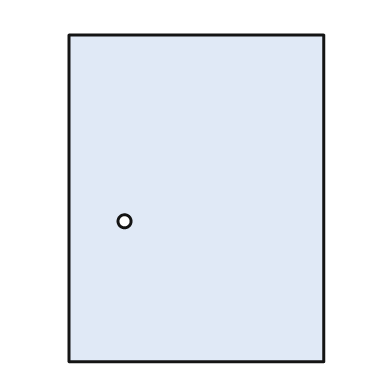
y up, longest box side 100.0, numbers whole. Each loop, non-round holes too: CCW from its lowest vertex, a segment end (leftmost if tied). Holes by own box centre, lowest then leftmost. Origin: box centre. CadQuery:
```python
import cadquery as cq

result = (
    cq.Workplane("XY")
    .moveTo(-39.0, -50.0)
    .lineTo(39.0, -50.0)
    .lineTo(39.0, 50.0)
    .lineTo(-39.0, 50.0)
    .close()
    .moveTo(-22.0, -7.0)
    .circle(2.0)
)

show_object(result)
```